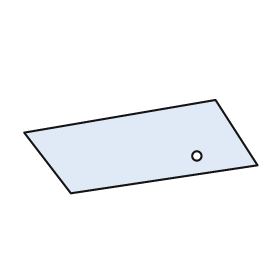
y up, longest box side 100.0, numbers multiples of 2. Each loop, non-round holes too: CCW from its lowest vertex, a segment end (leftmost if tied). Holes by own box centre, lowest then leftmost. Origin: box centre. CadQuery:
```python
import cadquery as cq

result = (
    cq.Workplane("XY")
    .moveTo(-30.0, -20.0)
    .lineTo(50.0, -8.0)
    .lineTo(32.0, 20.0)
    .lineTo(-50.0, 6.0)
    .close()
    .moveTo(24.0, -4.0)
    .circle(2.0)
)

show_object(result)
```